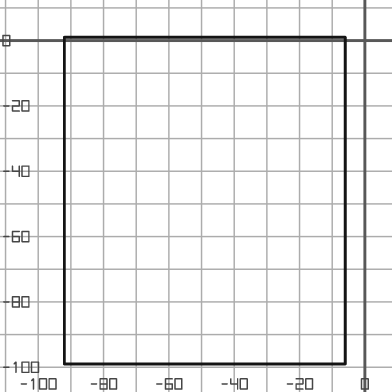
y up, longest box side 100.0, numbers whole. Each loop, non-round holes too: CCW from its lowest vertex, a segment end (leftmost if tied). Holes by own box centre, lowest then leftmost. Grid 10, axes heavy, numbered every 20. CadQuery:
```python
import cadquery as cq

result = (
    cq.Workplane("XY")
    .moveTo(-92.0, -99.0)
    .lineTo(-6.0, -99.0)
    .lineTo(-6.0, 1.0)
    .lineTo(-92.0, 1.0)
    .close()
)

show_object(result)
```